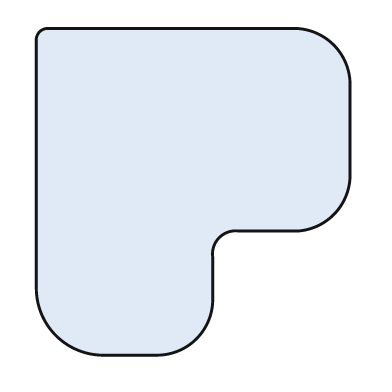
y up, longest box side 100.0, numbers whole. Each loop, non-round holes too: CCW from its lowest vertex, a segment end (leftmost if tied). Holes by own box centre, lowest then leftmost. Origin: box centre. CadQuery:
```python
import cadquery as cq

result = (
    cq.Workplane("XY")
    .moveTo(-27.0, -50.0)
    .lineTo(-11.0, -50.0)
    .threePointArc((1.0, -45.0), (6.0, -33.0))
    .lineTo(6.0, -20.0)
    .threePointArc((8.0, -14.0), (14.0, -12.0))
    .lineTo(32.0, -12.0)
    .threePointArc((43.0, -7.0), (48.0, 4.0))
    .lineTo(48.0, 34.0)
    .threePointArc((43.0, 45.0), (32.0, 50.0))
    .lineTo(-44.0, 50.0)
    .threePointArc((-47.0, 49.0), (-48.0, 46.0))
    .lineTo(-48.0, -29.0)
    .threePointArc((-42.0, -44.0), (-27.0, -50.0))
    .close()
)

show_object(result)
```